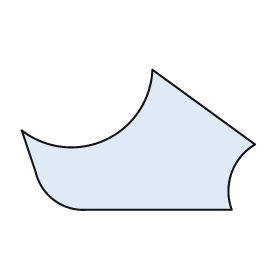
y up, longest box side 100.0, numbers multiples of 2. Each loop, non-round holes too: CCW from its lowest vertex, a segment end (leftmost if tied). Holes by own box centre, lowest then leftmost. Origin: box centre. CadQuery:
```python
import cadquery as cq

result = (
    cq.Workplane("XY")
    .moveTo(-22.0, -30.0)
    .lineTo(40.0, -30.0)
    .threePointArc((40.0, -14.0), (50.0, -2.0))
    .lineTo(6.0, 30.0)
    .threePointArc((-14.0, 0.0), (-50.0, 4.0))
    .lineTo(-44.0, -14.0)
    .threePointArc((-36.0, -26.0), (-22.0, -30.0))
    .close()
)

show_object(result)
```